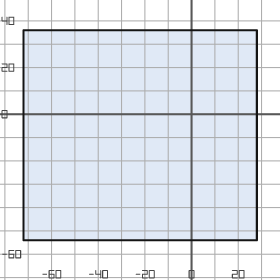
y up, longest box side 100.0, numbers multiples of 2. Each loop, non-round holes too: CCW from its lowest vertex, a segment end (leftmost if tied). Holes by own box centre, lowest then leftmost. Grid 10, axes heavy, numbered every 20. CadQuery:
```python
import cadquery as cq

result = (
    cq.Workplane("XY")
    .moveTo(-72.0, -54.0)
    .lineTo(28.0, -54.0)
    .lineTo(28.0, 36.0)
    .lineTo(-72.0, 36.0)
    .close()
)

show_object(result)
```